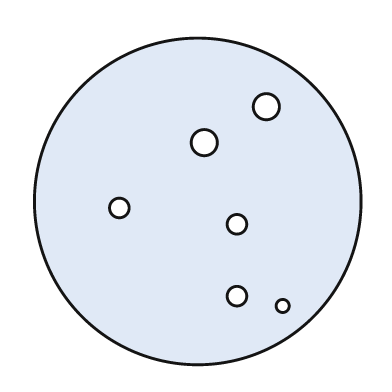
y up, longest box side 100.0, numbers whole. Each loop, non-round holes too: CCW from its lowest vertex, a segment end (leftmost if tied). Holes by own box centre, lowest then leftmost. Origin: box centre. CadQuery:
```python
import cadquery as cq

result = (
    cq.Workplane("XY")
    .moveTo(0.0, 0.0)
    .circle(50.0)
    .moveTo(26.0, -32.0)
    .circle(2.0)
    .moveTo(12.0, -29.0)
    .circle(3.0)
    .moveTo(12.0, -7.0)
    .circle(3.0)
    .moveTo(-24.0, -2.0)
    .circle(3.0)
    .moveTo(2.0, 18.0)
    .circle(4.0)
    .moveTo(21.0, 29.0)
    .circle(4.0)
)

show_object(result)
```